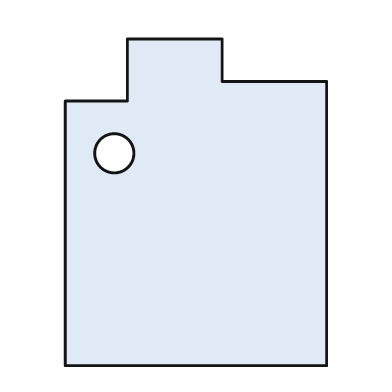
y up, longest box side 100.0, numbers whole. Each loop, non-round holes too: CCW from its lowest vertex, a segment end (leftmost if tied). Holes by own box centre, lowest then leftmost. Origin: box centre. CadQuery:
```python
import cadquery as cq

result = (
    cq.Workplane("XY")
    .moveTo(-40.0, -50.0)
    .lineTo(40.0, -50.0)
    .lineTo(40.0, 37.0)
    .lineTo(8.0, 37.0)
    .lineTo(8.0, 50.0)
    .lineTo(-21.0, 50.0)
    .lineTo(-21.0, 31.0)
    .lineTo(-40.0, 31.0)
    .close()
    .moveTo(-25.0, 15.0)
    .circle(6.0)
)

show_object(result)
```